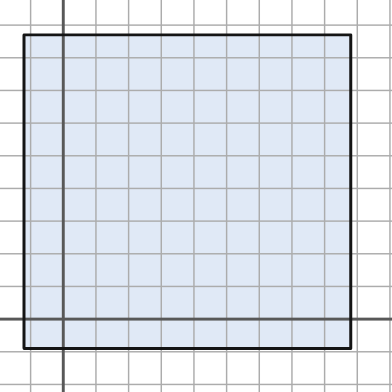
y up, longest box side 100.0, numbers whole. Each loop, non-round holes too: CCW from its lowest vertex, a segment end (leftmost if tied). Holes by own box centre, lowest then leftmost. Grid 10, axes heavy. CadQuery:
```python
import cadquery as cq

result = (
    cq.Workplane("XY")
    .moveTo(-12.0, -9.0)
    .lineTo(88.0, -9.0)
    .lineTo(88.0, 87.0)
    .lineTo(-12.0, 87.0)
    .close()
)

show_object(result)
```